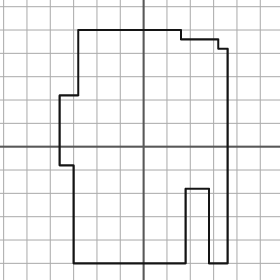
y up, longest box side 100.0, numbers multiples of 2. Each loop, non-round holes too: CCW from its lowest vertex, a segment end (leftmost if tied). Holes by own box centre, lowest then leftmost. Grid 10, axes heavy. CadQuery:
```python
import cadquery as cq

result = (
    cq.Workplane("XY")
    .moveTo(-30.0, -50.0)
    .lineTo(18.0, -50.0)
    .lineTo(18.0, -18.0)
    .lineTo(28.0, -18.0)
    .lineTo(28.0, -50.0)
    .lineTo(36.0, -50.0)
    .lineTo(36.0, 42.0)
    .lineTo(32.0, 42.0)
    .lineTo(32.0, 46.0)
    .lineTo(16.0, 46.0)
    .lineTo(16.0, 50.0)
    .lineTo(-28.0, 50.0)
    .lineTo(-28.0, 22.0)
    .lineTo(-36.0, 22.0)
    .lineTo(-36.0, -8.0)
    .lineTo(-30.0, -8.0)
    .close()
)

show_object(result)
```